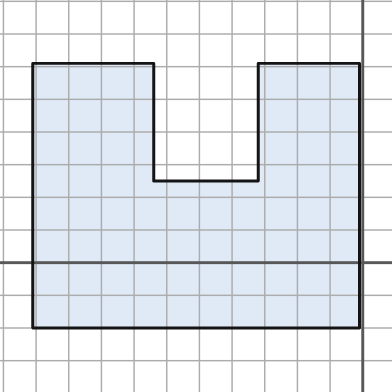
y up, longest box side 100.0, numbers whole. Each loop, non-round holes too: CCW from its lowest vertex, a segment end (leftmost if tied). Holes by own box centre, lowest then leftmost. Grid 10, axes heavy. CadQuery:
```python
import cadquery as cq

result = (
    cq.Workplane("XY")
    .moveTo(-101.0, -20.0)
    .lineTo(-1.0, -20.0)
    .lineTo(-1.0, 61.0)
    .lineTo(-32.0, 61.0)
    .lineTo(-32.0, 25.0)
    .lineTo(-64.0, 25.0)
    .lineTo(-64.0, 61.0)
    .lineTo(-101.0, 61.0)
    .close()
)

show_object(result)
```